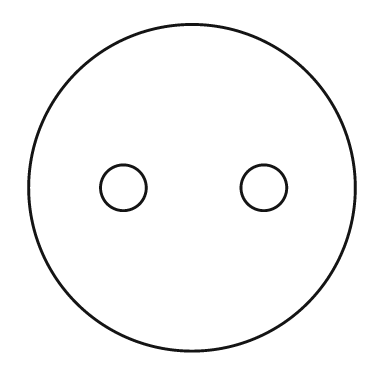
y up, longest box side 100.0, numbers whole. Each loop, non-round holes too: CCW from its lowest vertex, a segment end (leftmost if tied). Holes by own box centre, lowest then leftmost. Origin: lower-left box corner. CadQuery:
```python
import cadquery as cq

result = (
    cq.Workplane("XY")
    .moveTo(50.0, 50.0)
    .circle(50.0)
    .moveTo(29.0, 50.0)
    .circle(7.0)
    .moveTo(72.0, 50.0)
    .circle(7.0)
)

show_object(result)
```